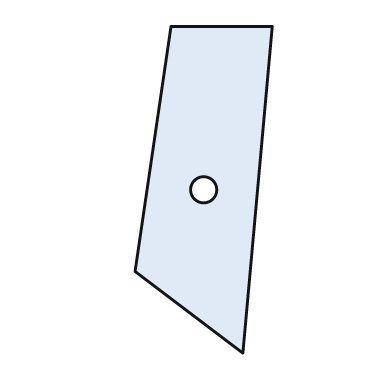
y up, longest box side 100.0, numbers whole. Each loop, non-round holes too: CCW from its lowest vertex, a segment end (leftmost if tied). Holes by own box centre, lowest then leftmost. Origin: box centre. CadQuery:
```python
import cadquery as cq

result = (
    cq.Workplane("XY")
    .moveTo(12.0, -50.0)
    .lineTo(21.0, 50.0)
    .lineTo(-10.0, 50.0)
    .lineTo(-21.0, -25.0)
    .close()
    .moveTo(0.0, 0.0)
    .circle(4.0)
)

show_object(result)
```